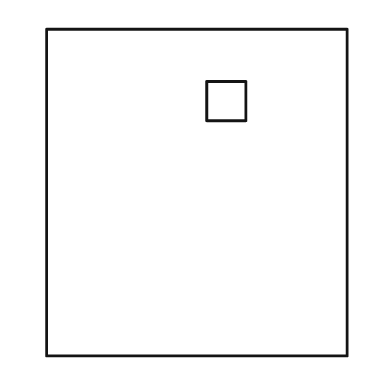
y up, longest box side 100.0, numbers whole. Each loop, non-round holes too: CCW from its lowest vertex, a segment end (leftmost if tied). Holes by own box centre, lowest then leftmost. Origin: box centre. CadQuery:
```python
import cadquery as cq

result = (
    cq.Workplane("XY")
    .moveTo(-46.0, -50.0)
    .lineTo(46.0, -50.0)
    .lineTo(46.0, 50.0)
    .lineTo(-46.0, 50.0)
    .close()
    .moveTo(3.0, 22.0)
    .lineTo(15.0, 22.0)
    .lineTo(15.0, 34.0)
    .lineTo(3.0, 34.0)
    .close()
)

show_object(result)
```